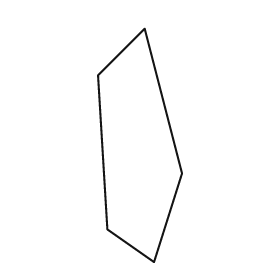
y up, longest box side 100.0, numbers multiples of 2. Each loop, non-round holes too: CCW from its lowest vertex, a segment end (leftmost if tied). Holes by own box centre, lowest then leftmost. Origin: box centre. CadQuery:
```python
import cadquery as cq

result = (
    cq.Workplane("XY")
    .moveTo(6.0, -50.0)
    .lineTo(18.0, -12.0)
    .lineTo(2.0, 50.0)
    .lineTo(-18.0, 30.0)
    .lineTo(-14.0, -36.0)
    .close()
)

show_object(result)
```